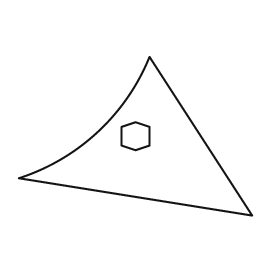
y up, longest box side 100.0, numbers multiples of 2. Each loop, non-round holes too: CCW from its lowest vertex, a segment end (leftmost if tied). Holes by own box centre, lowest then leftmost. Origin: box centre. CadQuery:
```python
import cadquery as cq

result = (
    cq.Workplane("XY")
    .moveTo(50.0, -34.0)
    .lineTo(6.0, 34.0)
    .threePointArc((-16.0, 2.0), (-50.0, -18.0))
    .close()
    .moveTo(0.0, -6.0)
    .lineTo(6.0, -4.0)
    .lineTo(6.0, 4.0)
    .lineTo(0.0, 6.0)
    .lineTo(-6.0, 4.0)
    .lineTo(-6.0, -4.0)
    .close()
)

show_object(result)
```